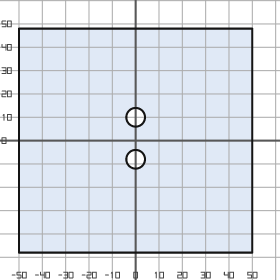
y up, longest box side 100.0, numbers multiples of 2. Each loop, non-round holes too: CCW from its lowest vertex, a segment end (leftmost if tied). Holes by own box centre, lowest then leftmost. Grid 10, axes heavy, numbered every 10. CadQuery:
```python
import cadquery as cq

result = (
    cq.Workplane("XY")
    .moveTo(-50.0, -48.0)
    .lineTo(50.0, -48.0)
    .lineTo(50.0, 48.0)
    .lineTo(-50.0, 48.0)
    .close()
    .moveTo(0.0, -8.0)
    .circle(4.0)
    .moveTo(0.0, 10.0)
    .circle(4.0)
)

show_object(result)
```